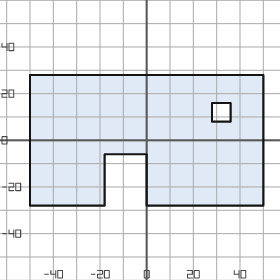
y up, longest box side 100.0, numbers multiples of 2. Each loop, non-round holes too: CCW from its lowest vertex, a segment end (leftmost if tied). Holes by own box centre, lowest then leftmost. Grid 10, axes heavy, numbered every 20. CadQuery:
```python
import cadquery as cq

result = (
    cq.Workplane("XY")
    .moveTo(-50.0, -28.0)
    .lineTo(-18.0, -28.0)
    .lineTo(-18.0, -6.0)
    .lineTo(0.0, -6.0)
    .lineTo(0.0, -28.0)
    .lineTo(50.0, -28.0)
    .lineTo(50.0, 28.0)
    .lineTo(-50.0, 28.0)
    .close()
    .moveTo(28.0, 8.0)
    .lineTo(36.0, 8.0)
    .lineTo(36.0, 16.0)
    .lineTo(28.0, 16.0)
    .close()
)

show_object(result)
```